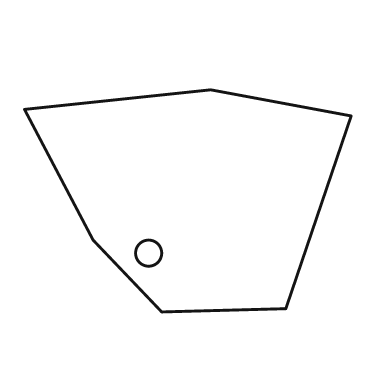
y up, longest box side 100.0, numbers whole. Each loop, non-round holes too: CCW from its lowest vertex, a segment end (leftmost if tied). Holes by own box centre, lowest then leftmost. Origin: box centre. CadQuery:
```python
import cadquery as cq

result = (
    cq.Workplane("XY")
    .moveTo(-8.0, -34.0)
    .lineTo(30.0, -33.0)
    .lineTo(50.0, 26.0)
    .lineTo(7.0, 34.0)
    .lineTo(-50.0, 28.0)
    .lineTo(-29.0, -12.0)
    .close()
    .moveTo(-12.0, -16.0)
    .circle(4.0)
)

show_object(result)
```